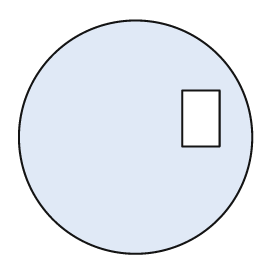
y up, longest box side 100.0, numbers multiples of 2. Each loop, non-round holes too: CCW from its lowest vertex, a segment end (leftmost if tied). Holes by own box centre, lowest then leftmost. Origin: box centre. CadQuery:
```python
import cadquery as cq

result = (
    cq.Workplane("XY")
    .moveTo(0.0, 0.0)
    .circle(50.0)
    .moveTo(20.0, -4.0)
    .lineTo(36.0, -4.0)
    .lineTo(36.0, 20.0)
    .lineTo(20.0, 20.0)
    .close()
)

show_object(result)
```